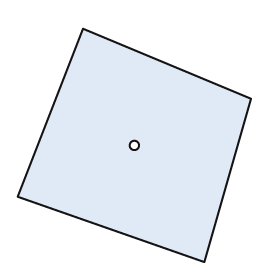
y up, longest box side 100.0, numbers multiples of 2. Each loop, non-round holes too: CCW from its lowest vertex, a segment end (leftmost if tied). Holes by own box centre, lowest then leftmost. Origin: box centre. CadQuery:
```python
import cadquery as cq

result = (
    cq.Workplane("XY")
    .moveTo(30.0, -50.0)
    .lineTo(50.0, 20.0)
    .lineTo(-22.0, 50.0)
    .lineTo(-50.0, -22.0)
    .close()
    .moveTo(0.0, 0.0)
    .circle(2.0)
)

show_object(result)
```